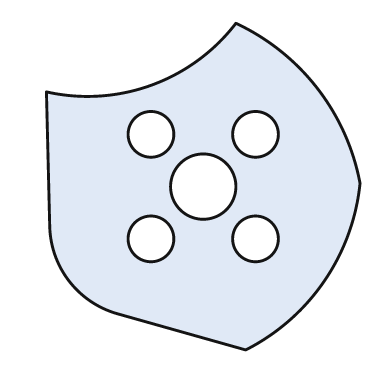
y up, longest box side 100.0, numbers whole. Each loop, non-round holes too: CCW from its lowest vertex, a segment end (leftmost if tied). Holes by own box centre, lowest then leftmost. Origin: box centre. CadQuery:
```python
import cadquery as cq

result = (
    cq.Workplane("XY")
    .moveTo(13.0, -50.0)
    .threePointArc((37.0, -29.0), (48.0, 1.0))
    .threePointArc((35.0, 30.0), (10.0, 50.0))
    .threePointArc((-16.0, 31.0), (-48.0, 29.0))
    .lineTo(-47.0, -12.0)
    .threePointArc((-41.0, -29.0), (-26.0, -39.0))
    .close()
    .moveTo(-16.0, -16.0)
    .circle(7.0)
    .moveTo(16.0, -16.0)
    .circle(7.0)
    .moveTo(0.0, 0.0)
    .circle(10.0)
    .moveTo(-16.0, 16.0)
    .circle(7.0)
    .moveTo(16.0, 16.0)
    .circle(7.0)
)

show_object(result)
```